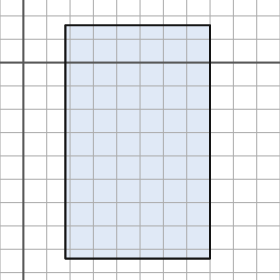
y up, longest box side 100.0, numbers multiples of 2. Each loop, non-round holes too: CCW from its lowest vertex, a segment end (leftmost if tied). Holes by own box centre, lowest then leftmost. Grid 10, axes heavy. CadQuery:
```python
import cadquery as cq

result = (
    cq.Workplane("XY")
    .moveTo(18.0, -84.0)
    .lineTo(80.0, -84.0)
    .lineTo(80.0, 16.0)
    .lineTo(18.0, 16.0)
    .close()
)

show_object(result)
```